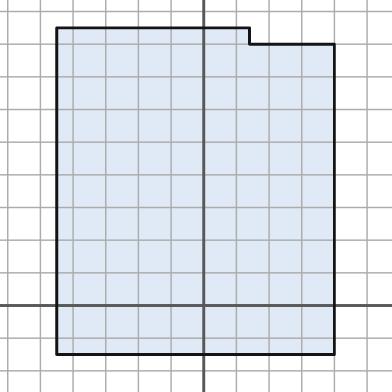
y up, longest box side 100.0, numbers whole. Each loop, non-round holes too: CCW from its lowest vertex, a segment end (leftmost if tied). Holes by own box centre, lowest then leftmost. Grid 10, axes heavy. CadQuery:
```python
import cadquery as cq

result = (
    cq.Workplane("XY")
    .moveTo(-45.0, -15.0)
    .lineTo(40.0, -15.0)
    .lineTo(40.0, 80.0)
    .lineTo(14.0, 80.0)
    .lineTo(14.0, 85.0)
    .lineTo(-45.0, 85.0)
    .close()
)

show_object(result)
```